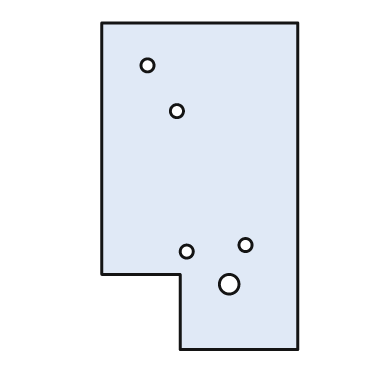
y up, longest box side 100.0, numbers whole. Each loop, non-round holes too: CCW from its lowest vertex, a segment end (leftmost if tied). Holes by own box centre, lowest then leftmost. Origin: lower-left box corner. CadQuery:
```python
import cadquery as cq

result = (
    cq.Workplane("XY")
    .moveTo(24.0, 0.0)
    .lineTo(60.0, 0.0)
    .lineTo(60.0, 100.0)
    .lineTo(0.0, 100.0)
    .lineTo(0.0, 23.0)
    .lineTo(24.0, 23.0)
    .close()
    .moveTo(39.0, 20.0)
    .circle(3.0)
    .moveTo(26.0, 30.0)
    .circle(2.0)
    .moveTo(44.0, 32.0)
    .circle(2.0)
    .moveTo(23.0, 73.0)
    .circle(2.0)
    .moveTo(14.0, 87.0)
    .circle(2.0)
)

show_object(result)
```